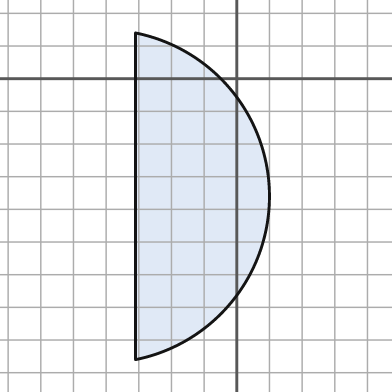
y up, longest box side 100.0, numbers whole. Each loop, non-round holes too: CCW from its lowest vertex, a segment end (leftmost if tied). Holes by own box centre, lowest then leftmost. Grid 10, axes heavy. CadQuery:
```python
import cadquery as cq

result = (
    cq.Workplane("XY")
    .moveTo(-31.0, -86.0)
    .threePointArc((10.0, -36.0), (-31.0, 14.0))
    .close()
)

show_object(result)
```